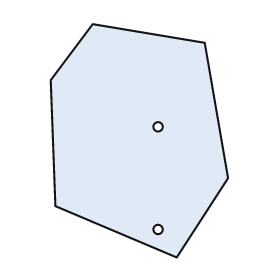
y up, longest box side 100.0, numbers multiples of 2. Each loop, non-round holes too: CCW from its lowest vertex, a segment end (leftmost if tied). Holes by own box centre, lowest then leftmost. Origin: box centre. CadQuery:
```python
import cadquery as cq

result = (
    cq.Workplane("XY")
    .moveTo(16.0, -50.0)
    .lineTo(38.0, -16.0)
    .lineTo(28.0, 42.0)
    .lineTo(-20.0, 50.0)
    .lineTo(-38.0, 26.0)
    .lineTo(-36.0, -28.0)
    .close()
    .moveTo(8.0, -38.0)
    .circle(2.0)
    .moveTo(8.0, 6.0)
    .circle(2.0)
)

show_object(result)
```